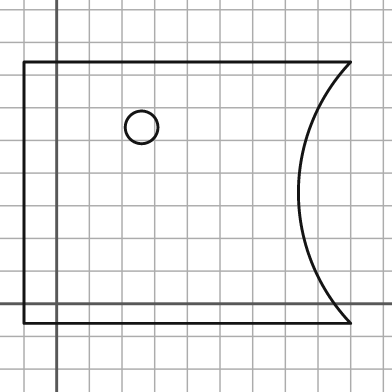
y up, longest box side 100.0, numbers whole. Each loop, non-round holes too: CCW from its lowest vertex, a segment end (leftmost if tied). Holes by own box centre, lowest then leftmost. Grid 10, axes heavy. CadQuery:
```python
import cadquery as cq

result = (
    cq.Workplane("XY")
    .moveTo(-10.0, -6.0)
    .lineTo(90.0, -6.0)
    .threePointArc((74.0, 34.0), (90.0, 74.0))
    .lineTo(-10.0, 74.0)
    .close()
    .moveTo(26.0, 54.0)
    .circle(5.0)
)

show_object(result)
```